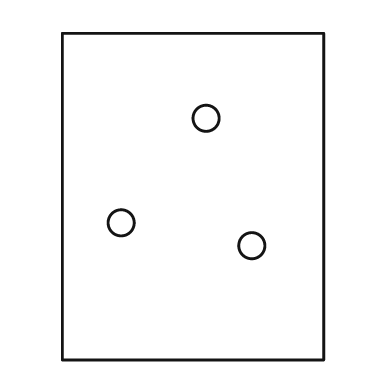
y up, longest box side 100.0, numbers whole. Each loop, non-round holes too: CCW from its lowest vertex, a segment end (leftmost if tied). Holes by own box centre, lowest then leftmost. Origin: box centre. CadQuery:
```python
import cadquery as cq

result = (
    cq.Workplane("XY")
    .moveTo(-40.0, -50.0)
    .lineTo(40.0, -50.0)
    .lineTo(40.0, 50.0)
    .lineTo(-40.0, 50.0)
    .close()
    .moveTo(18.0, -15.0)
    .circle(4.0)
    .moveTo(-22.0, -8.0)
    .circle(4.0)
    .moveTo(4.0, 24.0)
    .circle(4.0)
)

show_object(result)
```